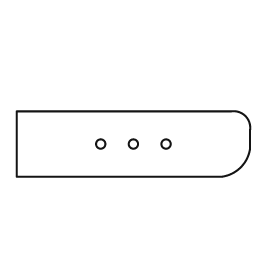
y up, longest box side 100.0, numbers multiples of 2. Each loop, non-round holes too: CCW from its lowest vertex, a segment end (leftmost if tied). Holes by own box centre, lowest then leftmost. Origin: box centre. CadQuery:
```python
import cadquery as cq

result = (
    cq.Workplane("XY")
    .moveTo(-50.0, -14.0)
    .lineTo(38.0, -14.0)
    .threePointArc((46.0, -10.0), (50.0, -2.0))
    .lineTo(50.0, 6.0)
    .threePointArc((48.0, 12.0), (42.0, 14.0))
    .lineTo(-50.0, 14.0)
    .close()
    .moveTo(-14.0, 0.0)
    .circle(2.0)
    .moveTo(0.0, 0.0)
    .circle(2.0)
    .moveTo(14.0, 0.0)
    .circle(2.0)
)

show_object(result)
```